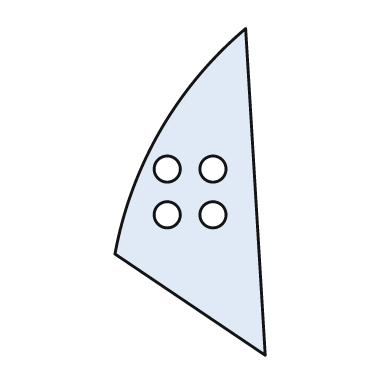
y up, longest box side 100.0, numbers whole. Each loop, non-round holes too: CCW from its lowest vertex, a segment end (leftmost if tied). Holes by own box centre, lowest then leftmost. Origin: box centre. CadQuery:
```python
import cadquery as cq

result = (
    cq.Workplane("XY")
    .moveTo(23.0, -50.0)
    .lineTo(17.0, 50.0)
    .threePointArc((-9.0, 19.0), (-23.0, -19.0))
    .close()
    .moveTo(-7.0, -7.0)
    .circle(4.0)
    .moveTo(7.0, -7.0)
    .circle(4.0)
    .moveTo(-7.0, 7.0)
    .circle(4.0)
    .moveTo(7.0, 7.0)
    .circle(4.0)
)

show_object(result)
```